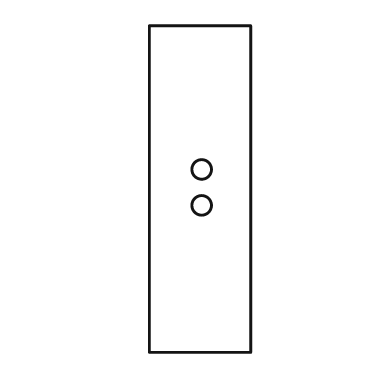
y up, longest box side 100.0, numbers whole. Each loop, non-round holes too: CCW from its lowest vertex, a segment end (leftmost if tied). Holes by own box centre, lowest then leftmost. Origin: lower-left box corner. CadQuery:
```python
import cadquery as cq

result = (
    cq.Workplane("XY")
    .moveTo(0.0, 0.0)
    .lineTo(31.0, 0.0)
    .lineTo(31.0, 100.0)
    .lineTo(0.0, 100.0)
    .close()
    .moveTo(16.0, 45.0)
    .circle(3.0)
    .moveTo(16.0, 56.0)
    .circle(3.0)
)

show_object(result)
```